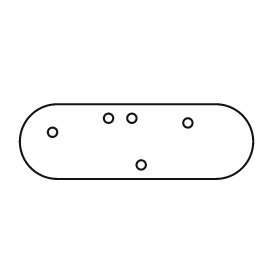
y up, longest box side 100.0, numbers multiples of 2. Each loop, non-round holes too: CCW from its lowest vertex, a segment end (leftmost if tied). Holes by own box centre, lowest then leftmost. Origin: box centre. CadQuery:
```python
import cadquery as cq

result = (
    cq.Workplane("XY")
    .moveTo(-34.0, -16.0)
    .lineTo(34.0, -16.0)
    .threePointArc((50.0, 0.0), (34.0, 16.0))
    .lineTo(-34.0, 16.0)
    .threePointArc((-50.0, 0.0), (-34.0, -16.0))
    .close()
    .moveTo(2.0, -10.0)
    .circle(2.0)
    .moveTo(-36.0, 4.0)
    .circle(2.0)
    .moveTo(22.0, 8.0)
    .circle(2.0)
    .moveTo(-12.0, 10.0)
    .circle(2.0)
    .moveTo(-2.0, 10.0)
    .circle(2.0)
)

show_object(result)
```